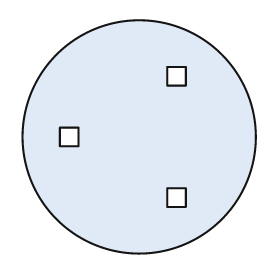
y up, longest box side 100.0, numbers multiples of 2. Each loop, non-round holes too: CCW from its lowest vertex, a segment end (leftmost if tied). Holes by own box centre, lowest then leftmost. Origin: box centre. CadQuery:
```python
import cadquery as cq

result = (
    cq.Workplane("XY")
    .moveTo(0.0, 0.0)
    .circle(50.0)
    .moveTo(12.0, -30.0)
    .lineTo(20.0, -30.0)
    .lineTo(20.0, -22.0)
    .lineTo(12.0, -22.0)
    .close()
    .moveTo(-34.0, -4.0)
    .lineTo(-26.0, -4.0)
    .lineTo(-26.0, 4.0)
    .lineTo(-34.0, 4.0)
    .close()
    .moveTo(12.0, 22.0)
    .lineTo(20.0, 22.0)
    .lineTo(20.0, 30.0)
    .lineTo(12.0, 30.0)
    .close()
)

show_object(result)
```